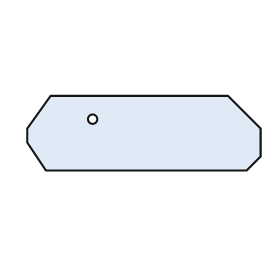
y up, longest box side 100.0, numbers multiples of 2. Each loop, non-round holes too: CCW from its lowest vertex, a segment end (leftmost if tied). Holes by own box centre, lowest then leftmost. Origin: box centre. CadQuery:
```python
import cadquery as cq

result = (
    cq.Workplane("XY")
    .moveTo(-42.0, -16.0)
    .lineTo(44.0, -16.0)
    .lineTo(50.0, -10.0)
    .lineTo(50.0, 2.0)
    .lineTo(36.0, 16.0)
    .lineTo(-40.0, 16.0)
    .lineTo(-50.0, 2.0)
    .lineTo(-50.0, -4.0)
    .close()
    .moveTo(-22.0, 6.0)
    .circle(2.0)
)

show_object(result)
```